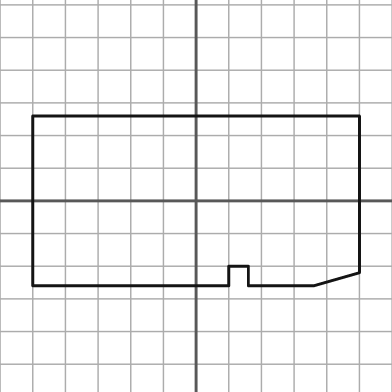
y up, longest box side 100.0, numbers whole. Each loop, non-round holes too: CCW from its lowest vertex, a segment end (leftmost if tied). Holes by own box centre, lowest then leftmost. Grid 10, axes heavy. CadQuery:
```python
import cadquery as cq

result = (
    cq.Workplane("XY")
    .moveTo(-50.0, -26.0)
    .lineTo(10.0, -26.0)
    .lineTo(10.0, -20.0)
    .lineTo(16.0, -20.0)
    .lineTo(16.0, -26.0)
    .lineTo(36.0, -26.0)
    .lineTo(50.0, -22.0)
    .lineTo(50.0, 26.0)
    .lineTo(-50.0, 26.0)
    .close()
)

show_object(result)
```